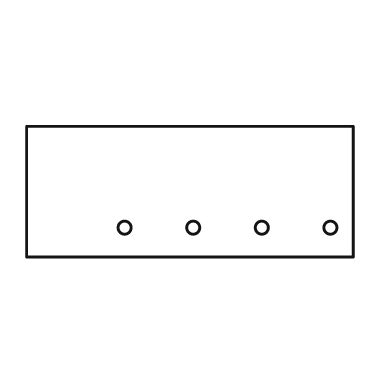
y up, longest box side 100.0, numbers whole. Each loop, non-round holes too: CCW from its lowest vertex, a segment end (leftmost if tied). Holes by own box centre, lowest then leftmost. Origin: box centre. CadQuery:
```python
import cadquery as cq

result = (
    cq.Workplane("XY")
    .moveTo(-50.0, -20.0)
    .lineTo(50.0, -20.0)
    .lineTo(50.0, 20.0)
    .lineTo(-50.0, 20.0)
    .close()
    .moveTo(-20.0, -11.0)
    .circle(2.0)
    .moveTo(1.0, -11.0)
    .circle(2.0)
    .moveTo(22.0, -11.0)
    .circle(2.0)
    .moveTo(43.0, -11.0)
    .circle(2.0)
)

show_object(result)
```